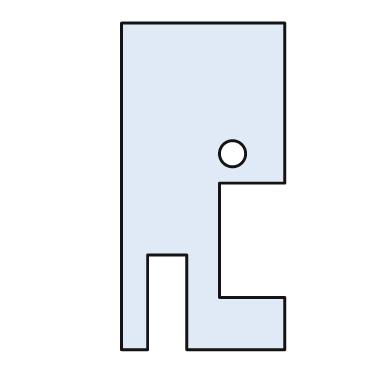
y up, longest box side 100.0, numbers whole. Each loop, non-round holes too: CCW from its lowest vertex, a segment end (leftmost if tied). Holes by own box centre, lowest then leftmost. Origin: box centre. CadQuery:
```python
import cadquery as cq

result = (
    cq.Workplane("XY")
    .moveTo(-25.0, -50.0)
    .lineTo(-17.0, -50.0)
    .lineTo(-17.0, -21.0)
    .lineTo(-5.0, -21.0)
    .lineTo(-5.0, -50.0)
    .lineTo(25.0, -50.0)
    .lineTo(25.0, -34.0)
    .lineTo(5.0, -34.0)
    .lineTo(5.0, 1.0)
    .lineTo(25.0, 1.0)
    .lineTo(25.0, 50.0)
    .lineTo(-25.0, 50.0)
    .close()
    .moveTo(9.0, 10.0)
    .circle(4.0)
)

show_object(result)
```